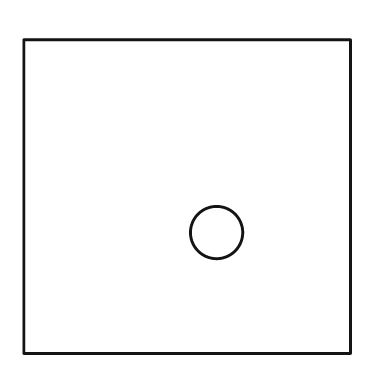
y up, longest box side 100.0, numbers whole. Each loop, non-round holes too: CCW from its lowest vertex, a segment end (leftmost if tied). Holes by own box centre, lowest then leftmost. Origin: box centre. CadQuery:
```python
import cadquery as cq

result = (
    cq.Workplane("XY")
    .moveTo(-50.0, -48.0)
    .lineTo(50.0, -48.0)
    .lineTo(50.0, 48.0)
    .lineTo(-50.0, 48.0)
    .close()
    .moveTo(9.0, -11.0)
    .circle(8.0)
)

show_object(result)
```